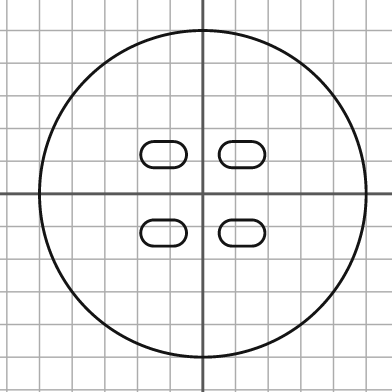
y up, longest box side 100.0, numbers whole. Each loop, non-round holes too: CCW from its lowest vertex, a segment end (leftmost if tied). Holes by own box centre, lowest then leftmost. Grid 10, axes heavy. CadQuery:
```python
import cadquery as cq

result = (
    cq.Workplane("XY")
    .moveTo(0.0, 0.0)
    .circle(50.0)
    .moveTo(-15.0, -16.0)
    .lineTo(-9.0, -16.0)
    .threePointArc((-5.0, -12.0), (-9.0, -8.0))
    .lineTo(-15.0, -8.0)
    .threePointArc((-19.0, -12.0), (-15.0, -16.0))
    .close()
    .moveTo(9.0, -16.0)
    .lineTo(15.0, -16.0)
    .threePointArc((19.0, -12.0), (15.0, -8.0))
    .lineTo(9.0, -8.0)
    .threePointArc((5.0, -12.0), (9.0, -16.0))
    .close()
    .moveTo(-15.0, 8.0)
    .lineTo(-9.0, 8.0)
    .threePointArc((-5.0, 12.0), (-9.0, 16.0))
    .lineTo(-15.0, 16.0)
    .threePointArc((-19.0, 12.0), (-15.0, 8.0))
    .close()
    .moveTo(9.0, 8.0)
    .lineTo(15.0, 8.0)
    .threePointArc((19.0, 12.0), (15.0, 16.0))
    .lineTo(9.0, 16.0)
    .threePointArc((5.0, 12.0), (9.0, 8.0))
    .close()
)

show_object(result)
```